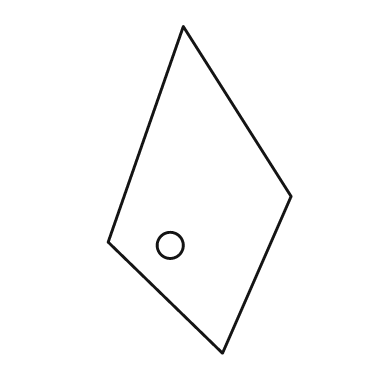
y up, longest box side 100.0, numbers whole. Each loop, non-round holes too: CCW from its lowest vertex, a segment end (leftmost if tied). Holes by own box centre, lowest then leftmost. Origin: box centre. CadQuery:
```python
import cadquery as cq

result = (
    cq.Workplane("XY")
    .moveTo(7.0, -50.0)
    .lineTo(28.0, -2.0)
    .lineTo(-5.0, 50.0)
    .lineTo(-28.0, -16.0)
    .close()
    .moveTo(-9.0, -17.0)
    .circle(4.0)
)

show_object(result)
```